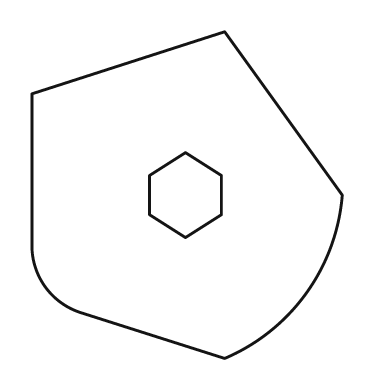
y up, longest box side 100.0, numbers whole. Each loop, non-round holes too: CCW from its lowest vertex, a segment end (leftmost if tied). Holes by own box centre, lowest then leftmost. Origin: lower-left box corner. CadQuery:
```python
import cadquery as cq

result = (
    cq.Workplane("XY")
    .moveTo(59.0, 0.0)
    .threePointArc((84.0, 20.0), (95.0, 50.0))
    .lineTo(59.0, 100.0)
    .lineTo(0.0, 81.0)
    .lineTo(0.0, 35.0)
    .threePointArc((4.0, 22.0), (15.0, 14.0))
    .close()
    .moveTo(47.0, 37.0)
    .lineTo(58.0, 44.0)
    .lineTo(58.0, 56.0)
    .lineTo(47.0, 63.0)
    .lineTo(36.0, 56.0)
    .lineTo(36.0, 44.0)
    .close()
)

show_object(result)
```